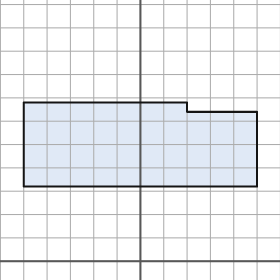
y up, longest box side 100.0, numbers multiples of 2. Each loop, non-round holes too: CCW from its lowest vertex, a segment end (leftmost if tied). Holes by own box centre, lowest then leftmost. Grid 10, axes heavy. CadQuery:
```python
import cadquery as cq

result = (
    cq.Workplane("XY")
    .moveTo(-50.0, 32.0)
    .lineTo(50.0, 32.0)
    .lineTo(50.0, 64.0)
    .lineTo(20.0, 64.0)
    .lineTo(20.0, 68.0)
    .lineTo(-50.0, 68.0)
    .close()
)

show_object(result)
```